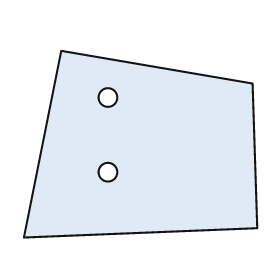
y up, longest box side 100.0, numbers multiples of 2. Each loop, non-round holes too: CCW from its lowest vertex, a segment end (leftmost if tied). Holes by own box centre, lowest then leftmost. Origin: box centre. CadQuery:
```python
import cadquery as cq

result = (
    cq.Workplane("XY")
    .moveTo(-50.0, -40.0)
    .lineTo(50.0, -36.0)
    .lineTo(48.0, 26.0)
    .lineTo(-34.0, 40.0)
    .close()
    .moveTo(-14.0, -12.0)
    .circle(4.0)
    .moveTo(-14.0, 20.0)
    .circle(4.0)
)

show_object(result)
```